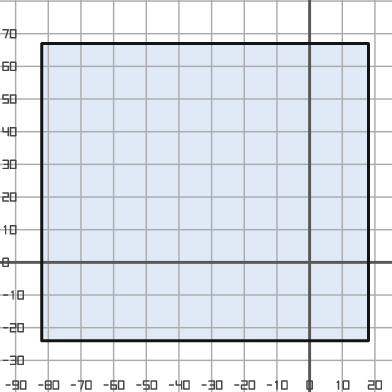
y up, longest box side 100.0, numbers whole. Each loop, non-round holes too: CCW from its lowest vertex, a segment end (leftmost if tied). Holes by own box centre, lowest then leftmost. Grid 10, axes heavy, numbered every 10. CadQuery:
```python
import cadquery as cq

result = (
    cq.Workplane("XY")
    .moveTo(-82.0, -24.0)
    .lineTo(18.0, -24.0)
    .lineTo(18.0, 67.0)
    .lineTo(-82.0, 67.0)
    .close()
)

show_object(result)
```